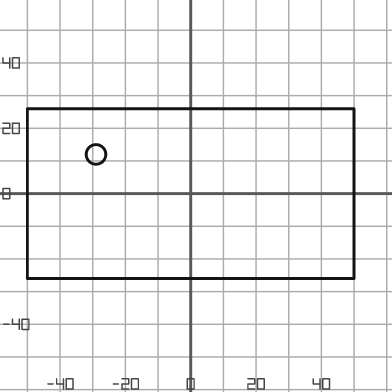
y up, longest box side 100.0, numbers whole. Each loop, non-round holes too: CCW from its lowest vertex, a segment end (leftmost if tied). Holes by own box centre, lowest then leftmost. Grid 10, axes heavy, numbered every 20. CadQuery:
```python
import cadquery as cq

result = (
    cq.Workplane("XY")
    .moveTo(-50.0, -26.0)
    .lineTo(50.0, -26.0)
    .lineTo(50.0, 26.0)
    .lineTo(-50.0, 26.0)
    .close()
    .moveTo(-29.0, 12.0)
    .circle(3.0)
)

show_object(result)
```